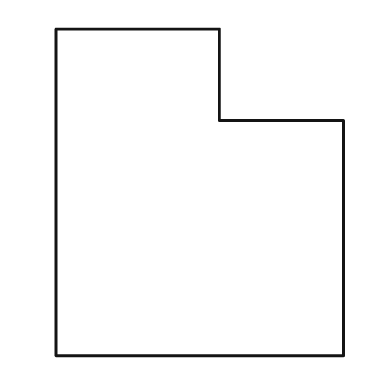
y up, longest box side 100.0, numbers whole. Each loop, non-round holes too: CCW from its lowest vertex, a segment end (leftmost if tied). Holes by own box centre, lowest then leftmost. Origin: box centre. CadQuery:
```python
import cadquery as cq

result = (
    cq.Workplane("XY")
    .moveTo(-44.0, -50.0)
    .lineTo(44.0, -50.0)
    .lineTo(44.0, 22.0)
    .lineTo(6.0, 22.0)
    .lineTo(6.0, 50.0)
    .lineTo(-44.0, 50.0)
    .close()
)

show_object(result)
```